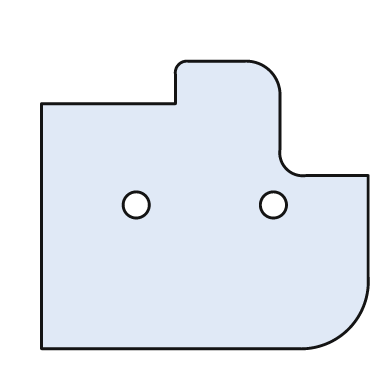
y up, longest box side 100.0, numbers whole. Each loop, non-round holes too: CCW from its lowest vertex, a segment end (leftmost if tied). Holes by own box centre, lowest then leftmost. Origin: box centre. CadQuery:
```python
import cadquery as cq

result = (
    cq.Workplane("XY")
    .moveTo(-50.0, -44.0)
    .lineTo(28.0, -44.0)
    .threePointArc((44.0, -38.0), (50.0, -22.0))
    .lineTo(50.0, 9.0)
    .lineTo(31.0, 9.0)
    .threePointArc((25.0, 11.0), (23.0, 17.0))
    .lineTo(23.0, 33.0)
    .threePointArc((20.0, 41.0), (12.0, 44.0))
    .lineTo(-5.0, 44.0)
    .threePointArc((-8.0, 43.0), (-9.0, 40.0))
    .lineTo(-9.0, 31.0)
    .lineTo(-50.0, 31.0)
    .close()
    .moveTo(-21.0, 0.0)
    .circle(4.0)
    .moveTo(21.0, 0.0)
    .circle(4.0)
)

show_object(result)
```